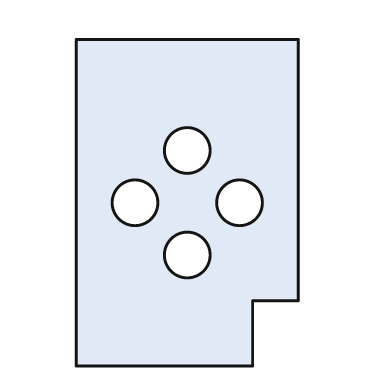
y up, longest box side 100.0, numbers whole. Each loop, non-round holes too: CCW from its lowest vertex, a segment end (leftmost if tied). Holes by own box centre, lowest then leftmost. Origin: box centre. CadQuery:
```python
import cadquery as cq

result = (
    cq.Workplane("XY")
    .moveTo(-34.0, -50.0)
    .lineTo(20.0, -50.0)
    .lineTo(20.0, -30.0)
    .lineTo(34.0, -30.0)
    .lineTo(34.0, 50.0)
    .lineTo(-34.0, 50.0)
    .close()
    .moveTo(0.0, -16.0)
    .circle(7.0)
    .moveTo(-16.0, 0.0)
    .circle(7.0)
    .moveTo(16.0, 0.0)
    .circle(7.0)
    .moveTo(0.0, 16.0)
    .circle(7.0)
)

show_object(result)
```